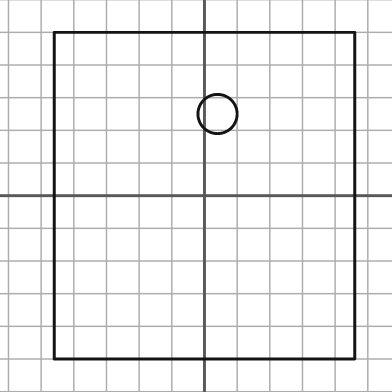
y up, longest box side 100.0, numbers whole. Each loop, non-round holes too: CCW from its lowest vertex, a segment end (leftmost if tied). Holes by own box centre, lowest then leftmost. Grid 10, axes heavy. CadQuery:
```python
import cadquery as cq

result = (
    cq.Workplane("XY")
    .moveTo(-46.0, -50.0)
    .lineTo(46.0, -50.0)
    .lineTo(46.0, 50.0)
    .lineTo(-46.0, 50.0)
    .close()
    .moveTo(4.0, 25.0)
    .circle(6.0)
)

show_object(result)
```